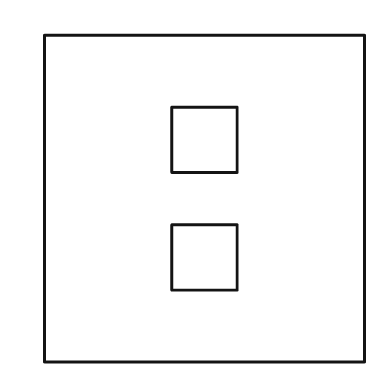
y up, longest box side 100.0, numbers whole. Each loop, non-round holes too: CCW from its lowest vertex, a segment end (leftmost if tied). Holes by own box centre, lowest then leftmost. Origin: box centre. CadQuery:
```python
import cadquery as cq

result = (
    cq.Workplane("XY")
    .moveTo(-49.0, -50.0)
    .lineTo(49.0, -50.0)
    .lineTo(49.0, 50.0)
    .lineTo(-49.0, 50.0)
    .close()
    .moveTo(-10.0, -28.0)
    .lineTo(10.0, -28.0)
    .lineTo(10.0, -8.0)
    .lineTo(-10.0, -8.0)
    .close()
    .moveTo(-10.0, 8.0)
    .lineTo(10.0, 8.0)
    .lineTo(10.0, 28.0)
    .lineTo(-10.0, 28.0)
    .close()
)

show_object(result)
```